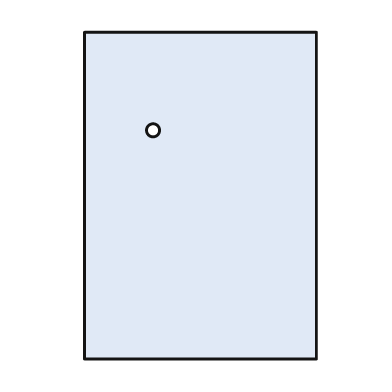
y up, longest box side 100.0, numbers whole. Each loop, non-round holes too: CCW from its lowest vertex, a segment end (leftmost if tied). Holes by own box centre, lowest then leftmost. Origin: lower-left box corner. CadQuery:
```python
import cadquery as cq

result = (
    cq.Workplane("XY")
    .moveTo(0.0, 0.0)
    .lineTo(71.0, 0.0)
    .lineTo(71.0, 100.0)
    .lineTo(0.0, 100.0)
    .close()
    .moveTo(21.0, 70.0)
    .circle(2.0)
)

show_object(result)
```